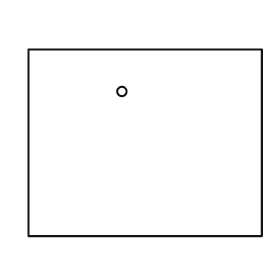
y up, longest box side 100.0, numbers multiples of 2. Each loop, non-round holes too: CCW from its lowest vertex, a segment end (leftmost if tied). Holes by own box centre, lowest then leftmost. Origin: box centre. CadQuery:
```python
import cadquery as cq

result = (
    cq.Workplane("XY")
    .moveTo(-50.0, -40.0)
    .lineTo(50.0, -40.0)
    .lineTo(50.0, 40.0)
    .lineTo(-50.0, 40.0)
    .close()
    .moveTo(-10.0, 22.0)
    .circle(2.0)
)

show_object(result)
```